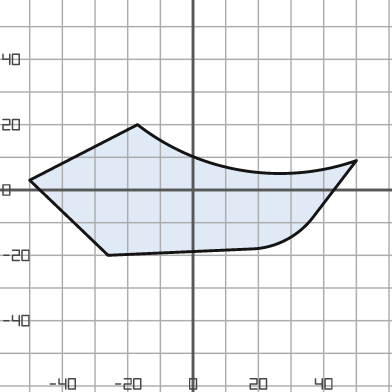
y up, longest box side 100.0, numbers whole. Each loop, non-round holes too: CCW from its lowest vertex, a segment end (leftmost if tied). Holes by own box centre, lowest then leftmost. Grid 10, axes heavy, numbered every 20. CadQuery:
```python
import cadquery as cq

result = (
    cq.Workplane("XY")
    .moveTo(-26.0, -20.0)
    .lineTo(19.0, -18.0)
    .threePointArc((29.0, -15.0), (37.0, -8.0))
    .lineTo(50.0, 9.0)
    .threePointArc((15.0, 6.0), (-17.0, 20.0))
    .lineTo(-50.0, 3.0)
    .close()
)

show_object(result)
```